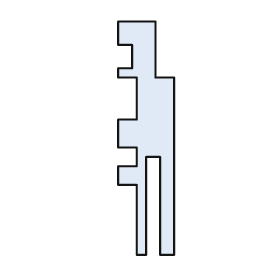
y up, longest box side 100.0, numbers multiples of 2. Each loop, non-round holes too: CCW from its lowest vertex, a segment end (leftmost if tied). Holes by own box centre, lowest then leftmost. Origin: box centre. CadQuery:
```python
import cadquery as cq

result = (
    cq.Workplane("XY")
    .moveTo(-4.0, -50.0)
    .lineTo(0.0, -50.0)
    .lineTo(0.0, -8.0)
    .lineTo(6.0, -8.0)
    .lineTo(6.0, -50.0)
    .lineTo(12.0, -50.0)
    .lineTo(12.0, 26.0)
    .lineTo(4.0, 26.0)
    .lineTo(4.0, 50.0)
    .lineTo(-12.0, 50.0)
    .lineTo(-12.0, 40.0)
    .lineTo(-6.0, 40.0)
    .lineTo(-6.0, 30.0)
    .lineTo(-12.0, 30.0)
    .lineTo(-12.0, 26.0)
    .lineTo(-4.0, 26.0)
    .lineTo(-4.0, 8.0)
    .lineTo(-12.0, 8.0)
    .lineTo(-12.0, -4.0)
    .lineTo(-4.0, -4.0)
    .lineTo(-4.0, -12.0)
    .lineTo(-12.0, -12.0)
    .lineTo(-12.0, -20.0)
    .lineTo(-4.0, -20.0)
    .close()
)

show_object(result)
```